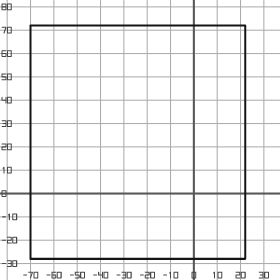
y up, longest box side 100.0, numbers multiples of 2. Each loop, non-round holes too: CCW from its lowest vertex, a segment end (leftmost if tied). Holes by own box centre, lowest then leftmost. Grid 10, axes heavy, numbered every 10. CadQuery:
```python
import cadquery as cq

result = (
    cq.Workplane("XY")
    .moveTo(-70.0, -28.0)
    .lineTo(22.0, -28.0)
    .lineTo(22.0, 72.0)
    .lineTo(-70.0, 72.0)
    .close()
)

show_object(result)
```